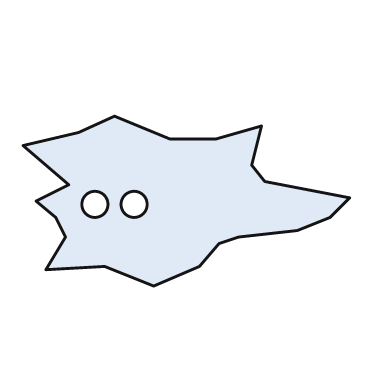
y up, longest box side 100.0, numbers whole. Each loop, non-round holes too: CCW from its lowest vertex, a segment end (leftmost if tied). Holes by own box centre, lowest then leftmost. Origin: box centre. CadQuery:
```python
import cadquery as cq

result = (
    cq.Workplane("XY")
    .moveTo(-10.0, -26.0)
    .lineTo(4.0, -20.0)
    .lineTo(10.0, -13.0)
    .lineTo(16.0, -11.0)
    .lineTo(34.0, -9.0)
    .lineTo(44.0, -5.0)
    .lineTo(50.0, 1.0)
    .lineTo(24.0, 6.0)
    .lineTo(20.0, 11.0)
    .lineTo(23.0, 23.0)
    .lineTo(9.0, 19.0)
    .lineTo(-5.0, 19.0)
    .lineTo(-22.0, 26.0)
    .lineTo(-33.0, 21.0)
    .lineTo(-50.0, 17.0)
    .lineTo(-36.0, 5.0)
    .lineTo(-46.0, 0.0)
    .lineTo(-40.0, -5.0)
    .lineTo(-37.0, -11.0)
    .lineTo(-43.0, -21.0)
    .lineTo(-25.0, -20.0)
    .close()
    .moveTo(-28.0, -1.0)
    .circle(4.0)
    .moveTo(-16.0, -1.0)
    .circle(4.0)
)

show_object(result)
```